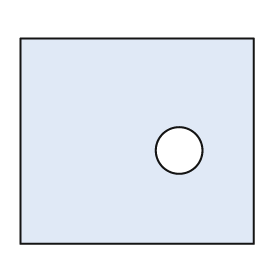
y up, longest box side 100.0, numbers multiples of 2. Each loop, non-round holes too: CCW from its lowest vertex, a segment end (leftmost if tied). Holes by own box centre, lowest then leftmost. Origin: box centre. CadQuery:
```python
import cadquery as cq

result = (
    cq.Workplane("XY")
    .moveTo(-50.0, -44.0)
    .lineTo(50.0, -44.0)
    .lineTo(50.0, 44.0)
    .lineTo(-50.0, 44.0)
    .close()
    .moveTo(18.0, -4.0)
    .circle(10.0)
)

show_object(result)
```